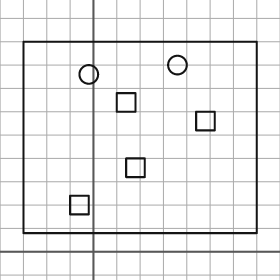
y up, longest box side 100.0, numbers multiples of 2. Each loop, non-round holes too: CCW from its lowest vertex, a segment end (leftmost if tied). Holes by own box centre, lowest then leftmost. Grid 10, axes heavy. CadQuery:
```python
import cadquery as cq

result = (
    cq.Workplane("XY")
    .moveTo(-30.0, 8.0)
    .lineTo(70.0, 8.0)
    .lineTo(70.0, 90.0)
    .lineTo(-30.0, 90.0)
    .close()
    .moveTo(-10.0, 16.0)
    .lineTo(-2.0, 16.0)
    .lineTo(-2.0, 24.0)
    .lineTo(-10.0, 24.0)
    .close()
    .moveTo(14.0, 32.0)
    .lineTo(22.0, 32.0)
    .lineTo(22.0, 40.0)
    .lineTo(14.0, 40.0)
    .close()
    .moveTo(44.0, 52.0)
    .lineTo(52.0, 52.0)
    .lineTo(52.0, 60.0)
    .lineTo(44.0, 60.0)
    .close()
    .moveTo(10.0, 60.0)
    .lineTo(18.0, 60.0)
    .lineTo(18.0, 68.0)
    .lineTo(10.0, 68.0)
    .close()
    .moveTo(-2.0, 76.0)
    .circle(4.0)
    .moveTo(36.0, 80.0)
    .circle(4.0)
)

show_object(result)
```